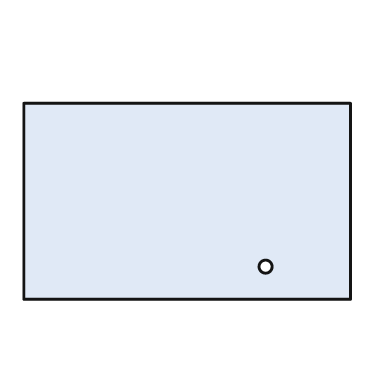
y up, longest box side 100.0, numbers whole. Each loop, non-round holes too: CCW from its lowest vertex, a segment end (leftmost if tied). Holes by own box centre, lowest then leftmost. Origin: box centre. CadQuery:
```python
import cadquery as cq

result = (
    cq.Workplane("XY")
    .moveTo(-50.0, -30.0)
    .lineTo(50.0, -30.0)
    .lineTo(50.0, 30.0)
    .lineTo(-50.0, 30.0)
    .close()
    .moveTo(24.0, -20.0)
    .circle(2.0)
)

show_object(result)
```